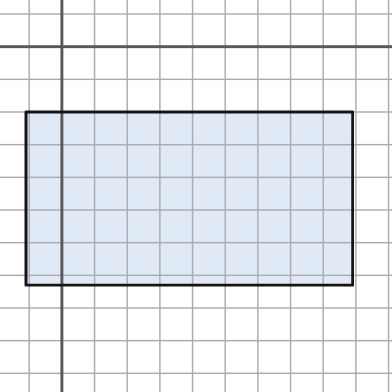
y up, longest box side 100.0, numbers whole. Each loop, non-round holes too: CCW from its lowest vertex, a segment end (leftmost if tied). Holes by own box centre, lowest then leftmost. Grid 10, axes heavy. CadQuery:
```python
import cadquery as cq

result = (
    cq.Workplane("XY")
    .moveTo(-11.0, -73.0)
    .lineTo(89.0, -73.0)
    .lineTo(89.0, -20.0)
    .lineTo(-11.0, -20.0)
    .close()
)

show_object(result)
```